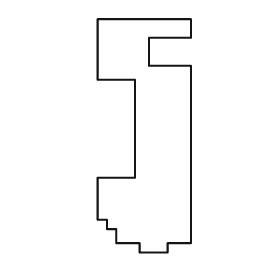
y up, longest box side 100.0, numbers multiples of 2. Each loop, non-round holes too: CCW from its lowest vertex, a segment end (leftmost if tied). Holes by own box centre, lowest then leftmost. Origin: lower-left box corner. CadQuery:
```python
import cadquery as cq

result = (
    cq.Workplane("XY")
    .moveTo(18.0, 0.0)
    .lineTo(30.0, 0.0)
    .lineTo(30.0, 4.0)
    .lineTo(40.0, 4.0)
    .lineTo(40.0, 80.0)
    .lineTo(22.0, 80.0)
    .lineTo(22.0, 92.0)
    .lineTo(40.0, 92.0)
    .lineTo(40.0, 100.0)
    .lineTo(0.0, 100.0)
    .lineTo(0.0, 74.0)
    .lineTo(16.0, 74.0)
    .lineTo(16.0, 32.0)
    .lineTo(0.0, 32.0)
    .lineTo(0.0, 14.0)
    .lineTo(4.0, 14.0)
    .lineTo(4.0, 10.0)
    .lineTo(8.0, 10.0)
    .lineTo(8.0, 4.0)
    .lineTo(18.0, 4.0)
    .close()
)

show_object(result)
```